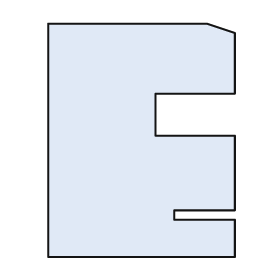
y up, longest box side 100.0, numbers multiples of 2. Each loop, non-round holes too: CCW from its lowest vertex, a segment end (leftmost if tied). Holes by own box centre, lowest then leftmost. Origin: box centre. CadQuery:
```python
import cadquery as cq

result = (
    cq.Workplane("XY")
    .moveTo(-40.0, -50.0)
    .lineTo(40.0, -50.0)
    .lineTo(40.0, -34.0)
    .lineTo(14.0, -34.0)
    .lineTo(14.0, -30.0)
    .lineTo(40.0, -30.0)
    .lineTo(40.0, 2.0)
    .lineTo(6.0, 2.0)
    .lineTo(6.0, 20.0)
    .lineTo(40.0, 20.0)
    .lineTo(40.0, 46.0)
    .lineTo(28.0, 50.0)
    .lineTo(-40.0, 50.0)
    .close()
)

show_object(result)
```